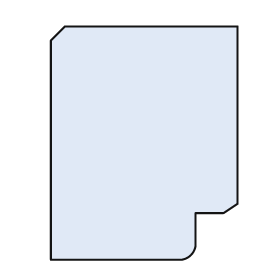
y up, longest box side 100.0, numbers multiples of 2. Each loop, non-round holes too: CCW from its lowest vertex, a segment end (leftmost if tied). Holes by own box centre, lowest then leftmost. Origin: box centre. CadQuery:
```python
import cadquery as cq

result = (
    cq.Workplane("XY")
    .moveTo(-40.0, -50.0)
    .lineTo(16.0, -50.0)
    .threePointArc((20.0, -48.0), (22.0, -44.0))
    .lineTo(22.0, -30.0)
    .lineTo(34.0, -30.0)
    .lineTo(40.0, -26.0)
    .lineTo(40.0, 50.0)
    .lineTo(-34.0, 50.0)
    .lineTo(-40.0, 44.0)
    .close()
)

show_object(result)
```